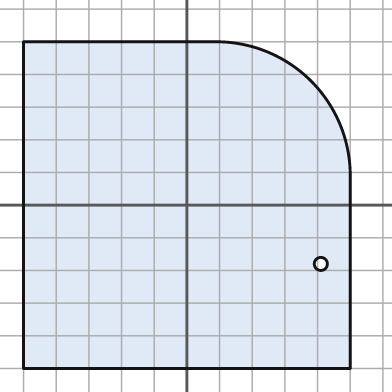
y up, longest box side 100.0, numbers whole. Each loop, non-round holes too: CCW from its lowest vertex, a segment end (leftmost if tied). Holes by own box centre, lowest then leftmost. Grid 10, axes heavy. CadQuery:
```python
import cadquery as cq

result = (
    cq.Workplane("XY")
    .moveTo(-50.0, -50.0)
    .lineTo(50.0, -50.0)
    .lineTo(50.0, 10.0)
    .threePointArc((38.0, 38.0), (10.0, 50.0))
    .lineTo(-50.0, 50.0)
    .close()
    .moveTo(41.0, -18.0)
    .circle(2.0)
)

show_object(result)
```